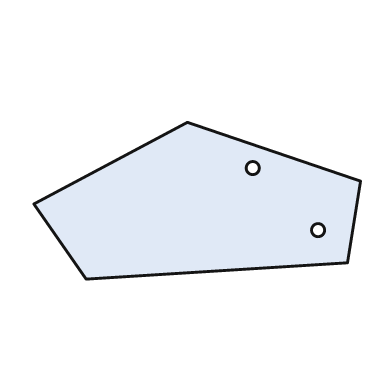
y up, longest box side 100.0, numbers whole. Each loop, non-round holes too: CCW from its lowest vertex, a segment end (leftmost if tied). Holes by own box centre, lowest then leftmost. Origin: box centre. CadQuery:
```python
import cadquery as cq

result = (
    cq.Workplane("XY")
    .moveTo(-34.0, -24.0)
    .lineTo(46.0, -19.0)
    .lineTo(50.0, 6.0)
    .lineTo(-3.0, 24.0)
    .lineTo(-50.0, -1.0)
    .close()
    .moveTo(37.0, -9.0)
    .circle(2.0)
    .moveTo(17.0, 10.0)
    .circle(2.0)
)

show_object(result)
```